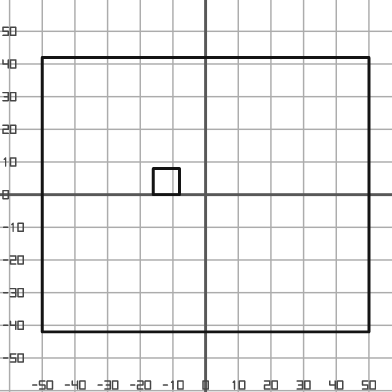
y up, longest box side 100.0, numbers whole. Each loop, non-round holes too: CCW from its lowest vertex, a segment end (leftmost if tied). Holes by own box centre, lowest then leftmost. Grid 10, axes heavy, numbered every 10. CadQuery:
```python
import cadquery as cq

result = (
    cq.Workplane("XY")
    .moveTo(-50.0, -42.0)
    .lineTo(50.0, -42.0)
    .lineTo(50.0, 42.0)
    .lineTo(-50.0, 42.0)
    .close()
    .moveTo(-16.0, 0.0)
    .lineTo(-8.0, 0.0)
    .lineTo(-8.0, 8.0)
    .lineTo(-16.0, 8.0)
    .close()
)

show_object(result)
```